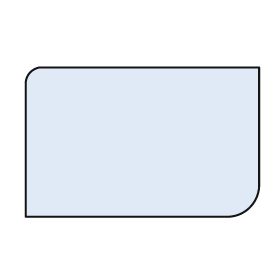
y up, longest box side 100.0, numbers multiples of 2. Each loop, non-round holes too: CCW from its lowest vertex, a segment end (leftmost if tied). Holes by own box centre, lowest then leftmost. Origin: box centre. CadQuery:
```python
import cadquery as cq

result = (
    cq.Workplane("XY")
    .moveTo(-50.0, -32.0)
    .lineTo(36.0, -32.0)
    .threePointArc((46.0, -28.0), (50.0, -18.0))
    .lineTo(50.0, 32.0)
    .lineTo(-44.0, 32.0)
    .threePointArc((-48.0, 30.0), (-50.0, 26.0))
    .close()
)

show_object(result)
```